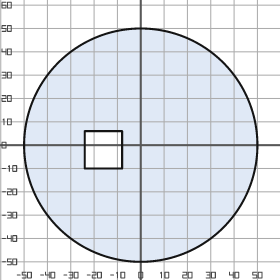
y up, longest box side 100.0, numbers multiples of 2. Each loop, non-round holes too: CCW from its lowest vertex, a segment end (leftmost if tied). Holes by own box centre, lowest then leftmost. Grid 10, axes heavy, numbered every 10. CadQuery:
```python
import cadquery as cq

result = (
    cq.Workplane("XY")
    .moveTo(0.0, 0.0)
    .circle(50.0)
    .moveTo(-24.0, -10.0)
    .lineTo(-8.0, -10.0)
    .lineTo(-8.0, 6.0)
    .lineTo(-24.0, 6.0)
    .close()
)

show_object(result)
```